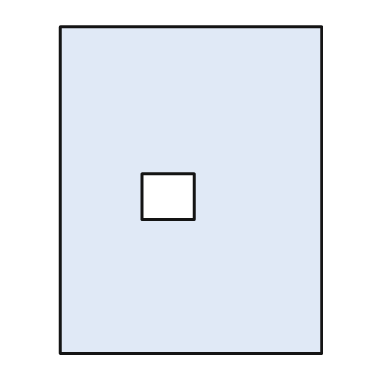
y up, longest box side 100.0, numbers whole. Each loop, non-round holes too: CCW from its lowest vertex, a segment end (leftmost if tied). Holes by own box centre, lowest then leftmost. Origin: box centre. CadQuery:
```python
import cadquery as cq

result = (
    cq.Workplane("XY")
    .moveTo(-40.0, -50.0)
    .lineTo(40.0, -50.0)
    .lineTo(40.0, 50.0)
    .lineTo(-40.0, 50.0)
    .close()
    .moveTo(-15.0, -9.0)
    .lineTo(1.0, -9.0)
    .lineTo(1.0, 5.0)
    .lineTo(-15.0, 5.0)
    .close()
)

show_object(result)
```